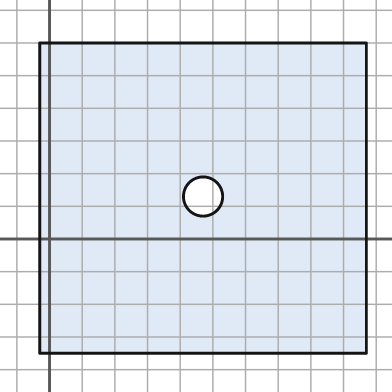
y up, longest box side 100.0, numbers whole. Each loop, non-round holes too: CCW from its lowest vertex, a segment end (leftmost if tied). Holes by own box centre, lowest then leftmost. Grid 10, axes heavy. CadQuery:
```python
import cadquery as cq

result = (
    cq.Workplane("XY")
    .moveTo(-3.0, -35.0)
    .lineTo(97.0, -35.0)
    .lineTo(97.0, 60.0)
    .lineTo(-3.0, 60.0)
    .close()
    .moveTo(47.0, 13.0)
    .circle(6.0)
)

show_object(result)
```